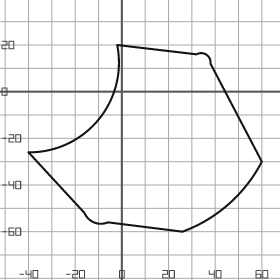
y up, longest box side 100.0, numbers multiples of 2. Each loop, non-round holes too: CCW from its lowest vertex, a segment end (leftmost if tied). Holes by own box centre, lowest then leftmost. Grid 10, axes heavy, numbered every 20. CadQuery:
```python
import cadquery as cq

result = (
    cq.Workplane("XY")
    .moveTo(26.0, -60.0)
    .threePointArc((46.0, -48.0), (60.0, -30.0))
    .lineTo(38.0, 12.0)
    .threePointArc((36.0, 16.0), (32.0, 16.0))
    .lineTo(-2.0, 20.0)
    .threePointArc((-10.0, -12.0), (-40.0, -26.0))
    .lineTo(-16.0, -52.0)
    .threePointArc((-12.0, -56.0), (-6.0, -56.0))
    .close()
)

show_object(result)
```